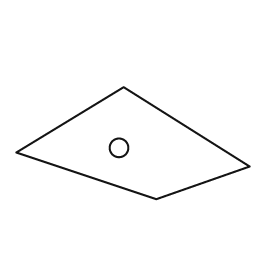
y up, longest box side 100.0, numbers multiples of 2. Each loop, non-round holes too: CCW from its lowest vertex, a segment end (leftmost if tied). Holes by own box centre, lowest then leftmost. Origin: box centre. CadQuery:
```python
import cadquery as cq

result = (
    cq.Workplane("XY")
    .moveTo(10.0, -24.0)
    .lineTo(50.0, -10.0)
    .lineTo(-4.0, 24.0)
    .lineTo(-50.0, -4.0)
    .close()
    .moveTo(-6.0, -2.0)
    .circle(4.0)
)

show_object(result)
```